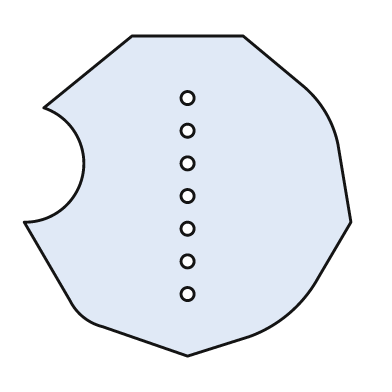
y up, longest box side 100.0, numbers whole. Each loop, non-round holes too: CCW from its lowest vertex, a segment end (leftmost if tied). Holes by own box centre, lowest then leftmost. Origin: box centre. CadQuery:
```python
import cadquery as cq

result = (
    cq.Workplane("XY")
    .moveTo(0.0, -49.0)
    .lineTo(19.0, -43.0)
    .threePointArc((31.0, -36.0), (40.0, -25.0))
    .lineTo(50.0, -8.0)
    .lineTo(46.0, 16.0)
    .threePointArc((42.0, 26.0), (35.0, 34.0))
    .lineTo(17.0, 49.0)
    .lineTo(-17.0, 49.0)
    .lineTo(-44.0, 27.0)
    .threePointArc((-32.0, 7.0), (-50.0, -8.0))
    .lineTo(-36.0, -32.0)
    .threePointArc((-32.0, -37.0), (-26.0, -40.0))
    .close()
    .moveTo(0.0, -30.0)
    .circle(2.0)
    .moveTo(0.0, -20.0)
    .circle(2.0)
    .moveTo(0.0, -10.0)
    .circle(2.0)
    .moveTo(0.0, 0.0)
    .circle(2.0)
    .moveTo(0.0, 10.0)
    .circle(2.0)
    .moveTo(0.0, 20.0)
    .circle(2.0)
    .moveTo(0.0, 30.0)
    .circle(2.0)
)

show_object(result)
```